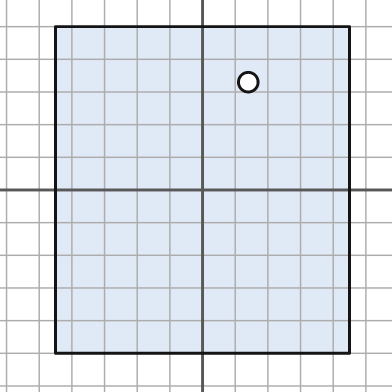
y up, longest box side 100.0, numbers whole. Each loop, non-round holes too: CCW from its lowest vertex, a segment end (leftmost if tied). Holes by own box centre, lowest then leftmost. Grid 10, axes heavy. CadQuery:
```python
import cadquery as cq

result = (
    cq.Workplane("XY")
    .moveTo(-45.0, -50.0)
    .lineTo(45.0, -50.0)
    .lineTo(45.0, 50.0)
    .lineTo(-45.0, 50.0)
    .close()
    .moveTo(14.0, 33.0)
    .circle(3.0)
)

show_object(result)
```